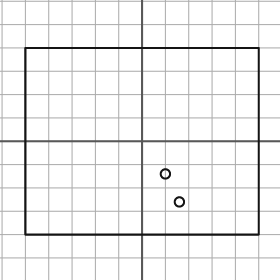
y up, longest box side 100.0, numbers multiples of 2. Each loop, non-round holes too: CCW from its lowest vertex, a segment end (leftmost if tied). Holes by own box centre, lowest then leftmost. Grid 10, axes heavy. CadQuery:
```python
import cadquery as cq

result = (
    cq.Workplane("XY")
    .moveTo(-50.0, -40.0)
    .lineTo(50.0, -40.0)
    .lineTo(50.0, 40.0)
    .lineTo(-50.0, 40.0)
    .close()
    .moveTo(16.0, -26.0)
    .circle(2.0)
    .moveTo(10.0, -14.0)
    .circle(2.0)
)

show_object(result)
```